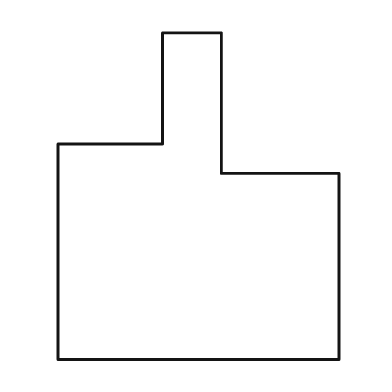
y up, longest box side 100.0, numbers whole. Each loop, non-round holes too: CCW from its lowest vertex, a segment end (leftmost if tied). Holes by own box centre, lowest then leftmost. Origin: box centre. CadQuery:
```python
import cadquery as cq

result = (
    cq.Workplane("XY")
    .moveTo(-43.0, -50.0)
    .lineTo(43.0, -50.0)
    .lineTo(43.0, 7.0)
    .lineTo(7.0, 7.0)
    .lineTo(7.0, 50.0)
    .lineTo(-11.0, 50.0)
    .lineTo(-11.0, 16.0)
    .lineTo(-43.0, 16.0)
    .close()
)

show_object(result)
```